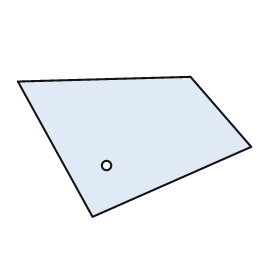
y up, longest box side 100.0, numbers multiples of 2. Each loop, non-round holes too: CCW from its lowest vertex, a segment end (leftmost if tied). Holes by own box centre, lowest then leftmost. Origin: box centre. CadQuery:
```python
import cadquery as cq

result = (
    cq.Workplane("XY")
    .moveTo(-18.0, -30.0)
    .lineTo(50.0, 0.0)
    .lineTo(24.0, 30.0)
    .lineTo(-50.0, 28.0)
    .close()
    .moveTo(-12.0, -8.0)
    .circle(2.0)
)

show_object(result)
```